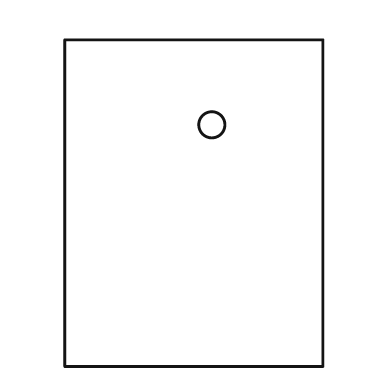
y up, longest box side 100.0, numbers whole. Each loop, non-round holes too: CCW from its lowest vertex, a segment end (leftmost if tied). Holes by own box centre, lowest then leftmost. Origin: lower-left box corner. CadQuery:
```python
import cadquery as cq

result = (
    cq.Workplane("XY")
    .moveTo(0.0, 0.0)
    .lineTo(79.0, 0.0)
    .lineTo(79.0, 100.0)
    .lineTo(0.0, 100.0)
    .close()
    .moveTo(45.0, 74.0)
    .circle(4.0)
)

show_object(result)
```